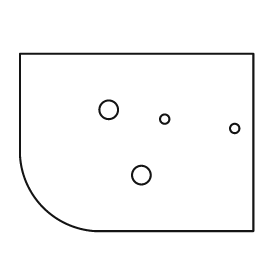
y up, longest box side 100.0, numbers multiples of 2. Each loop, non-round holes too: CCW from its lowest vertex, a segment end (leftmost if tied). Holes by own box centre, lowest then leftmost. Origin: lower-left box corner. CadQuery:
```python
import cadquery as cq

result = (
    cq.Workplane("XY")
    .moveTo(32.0, 0.0)
    .lineTo(100.0, 0.0)
    .lineTo(100.0, 76.0)
    .lineTo(0.0, 76.0)
    .lineTo(0.0, 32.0)
    .threePointArc((10.0, 10.0), (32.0, 0.0))
    .close()
    .moveTo(52.0, 24.0)
    .circle(4.0)
    .moveTo(92.0, 44.0)
    .circle(2.0)
    .moveTo(62.0, 48.0)
    .circle(2.0)
    .moveTo(38.0, 52.0)
    .circle(4.0)
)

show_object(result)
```